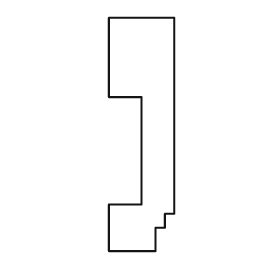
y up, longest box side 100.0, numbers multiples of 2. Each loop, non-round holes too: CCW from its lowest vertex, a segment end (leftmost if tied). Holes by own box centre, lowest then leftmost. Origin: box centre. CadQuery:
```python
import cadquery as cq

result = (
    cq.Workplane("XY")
    .moveTo(-14.0, -50.0)
    .lineTo(6.0, -50.0)
    .lineTo(6.0, -40.0)
    .lineTo(10.0, -40.0)
    .lineTo(10.0, -34.0)
    .lineTo(14.0, -34.0)
    .lineTo(14.0, 50.0)
    .lineTo(-14.0, 50.0)
    .lineTo(-14.0, 16.0)
    .lineTo(0.0, 16.0)
    .lineTo(0.0, -30.0)
    .lineTo(-14.0, -30.0)
    .close()
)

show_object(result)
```